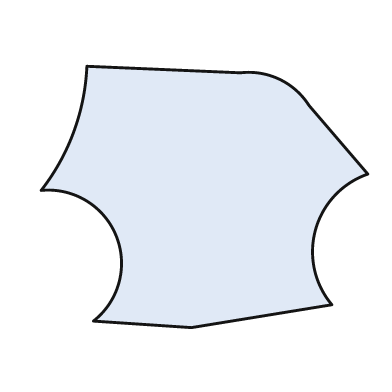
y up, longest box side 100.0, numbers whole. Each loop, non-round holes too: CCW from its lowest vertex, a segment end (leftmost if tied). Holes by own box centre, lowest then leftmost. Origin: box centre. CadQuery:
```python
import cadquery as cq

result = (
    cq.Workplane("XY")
    .moveTo(-4.0, -40.0)
    .lineTo(39.0, -33.0)
    .threePointArc((34.0, -10.0), (50.0, 7.0))
    .lineTo(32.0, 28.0)
    .threePointArc((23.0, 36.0), (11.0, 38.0))
    .lineTo(-36.0, 40.0)
    .threePointArc((-40.0, 20.0), (-50.0, 2.0))
    .threePointArc((-27.0, -12.0), (-34.0, -38.0))
    .close()
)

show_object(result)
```